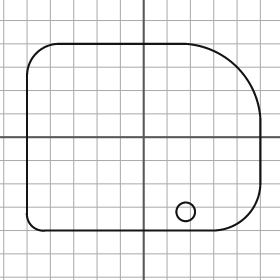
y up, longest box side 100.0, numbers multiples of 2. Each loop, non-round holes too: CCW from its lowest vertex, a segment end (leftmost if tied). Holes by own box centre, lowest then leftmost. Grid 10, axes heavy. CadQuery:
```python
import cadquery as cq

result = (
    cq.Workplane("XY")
    .moveTo(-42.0, -40.0)
    .lineTo(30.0, -40.0)
    .threePointArc((44.0, -34.0), (50.0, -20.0))
    .lineTo(50.0, 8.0)
    .threePointArc((40.0, 30.0), (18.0, 40.0))
    .lineTo(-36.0, 40.0)
    .threePointArc((-46.0, 36.0), (-50.0, 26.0))
    .lineTo(-50.0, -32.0)
    .threePointArc((-48.0, -38.0), (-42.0, -40.0))
    .close()
    .moveTo(18.0, -32.0)
    .circle(4.0)
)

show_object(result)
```